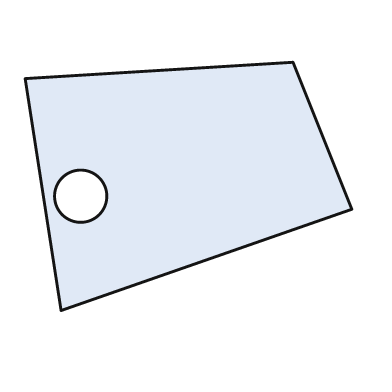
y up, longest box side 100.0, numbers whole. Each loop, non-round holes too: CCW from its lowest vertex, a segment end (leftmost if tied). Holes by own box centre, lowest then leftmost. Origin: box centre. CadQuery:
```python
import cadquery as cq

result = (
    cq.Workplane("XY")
    .moveTo(-39.0, -38.0)
    .lineTo(50.0, -7.0)
    .lineTo(32.0, 38.0)
    .lineTo(-50.0, 33.0)
    .close()
    .moveTo(-33.0, -3.0)
    .circle(8.0)
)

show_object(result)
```